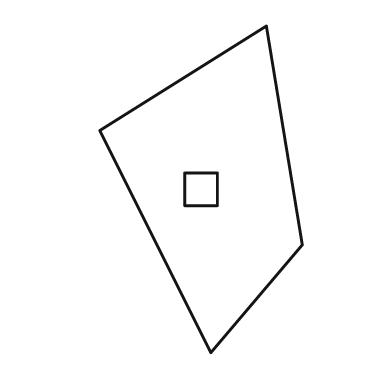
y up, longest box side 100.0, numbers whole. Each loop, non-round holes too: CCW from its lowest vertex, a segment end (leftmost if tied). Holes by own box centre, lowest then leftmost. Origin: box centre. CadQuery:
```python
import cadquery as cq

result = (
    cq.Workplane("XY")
    .moveTo(3.0, -50.0)
    .lineTo(31.0, -17.0)
    .lineTo(20.0, 50.0)
    .lineTo(-31.0, 18.0)
    .close()
    .moveTo(-5.0, -5.0)
    .lineTo(5.0, -5.0)
    .lineTo(5.0, 5.0)
    .lineTo(-5.0, 5.0)
    .close()
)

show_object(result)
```